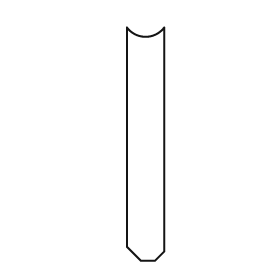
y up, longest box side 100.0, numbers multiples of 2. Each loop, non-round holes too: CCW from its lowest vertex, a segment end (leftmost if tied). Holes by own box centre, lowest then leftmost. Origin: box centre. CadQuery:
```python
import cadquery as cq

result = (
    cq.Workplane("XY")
    .moveTo(-2.0, -50.0)
    .lineTo(4.0, -50.0)
    .lineTo(8.0, -46.0)
    .lineTo(8.0, 50.0)
    .threePointArc((0.0, 46.0), (-8.0, 50.0))
    .lineTo(-8.0, -44.0)
    .close()
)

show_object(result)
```